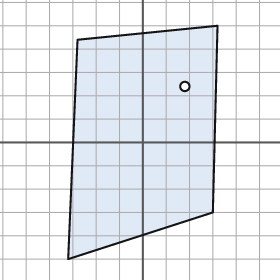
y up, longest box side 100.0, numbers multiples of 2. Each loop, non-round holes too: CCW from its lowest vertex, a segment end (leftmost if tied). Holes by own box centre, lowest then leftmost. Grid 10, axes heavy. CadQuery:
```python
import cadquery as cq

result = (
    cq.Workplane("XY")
    .moveTo(-32.0, -50.0)
    .lineTo(30.0, -30.0)
    .lineTo(32.0, 50.0)
    .lineTo(-28.0, 44.0)
    .close()
    .moveTo(18.0, 24.0)
    .circle(2.0)
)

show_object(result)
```